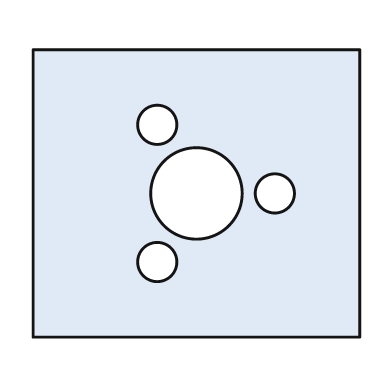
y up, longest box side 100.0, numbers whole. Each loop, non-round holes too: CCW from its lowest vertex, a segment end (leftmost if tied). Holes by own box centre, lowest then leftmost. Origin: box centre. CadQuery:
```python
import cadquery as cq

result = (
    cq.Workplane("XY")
    .moveTo(-50.0, -44.0)
    .lineTo(50.0, -44.0)
    .lineTo(50.0, 44.0)
    .lineTo(-50.0, 44.0)
    .close()
    .moveTo(-12.0, -21.0)
    .circle(6.0)
    .moveTo(0.0, 0.0)
    .circle(14.0)
    .moveTo(24.0, 0.0)
    .circle(6.0)
    .moveTo(-12.0, 21.0)
    .circle(6.0)
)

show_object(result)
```